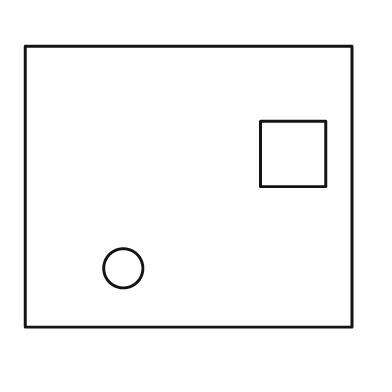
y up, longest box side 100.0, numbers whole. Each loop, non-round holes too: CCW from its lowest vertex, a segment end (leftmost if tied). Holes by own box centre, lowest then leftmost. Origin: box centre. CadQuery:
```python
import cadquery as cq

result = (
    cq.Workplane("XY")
    .moveTo(-50.0, -43.0)
    .lineTo(50.0, -43.0)
    .lineTo(50.0, 43.0)
    .lineTo(-50.0, 43.0)
    .close()
    .moveTo(-20.0, -25.0)
    .circle(6.0)
    .moveTo(22.0, 0.0)
    .lineTo(42.0, 0.0)
    .lineTo(42.0, 20.0)
    .lineTo(22.0, 20.0)
    .close()
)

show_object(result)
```